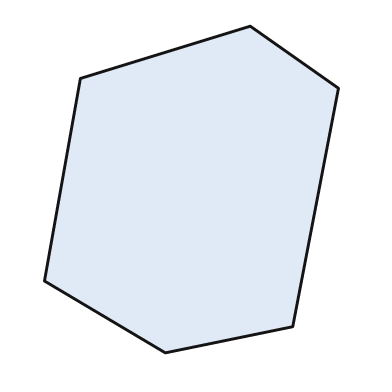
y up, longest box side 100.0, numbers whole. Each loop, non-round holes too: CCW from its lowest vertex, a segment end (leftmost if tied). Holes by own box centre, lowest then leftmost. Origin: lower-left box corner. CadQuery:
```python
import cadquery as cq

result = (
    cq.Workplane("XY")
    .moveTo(37.0, 0.0)
    .lineTo(76.0, 8.0)
    .lineTo(90.0, 81.0)
    .lineTo(63.0, 100.0)
    .lineTo(11.0, 84.0)
    .lineTo(0.0, 22.0)
    .close()
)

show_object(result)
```